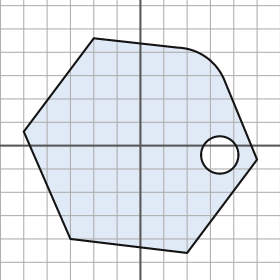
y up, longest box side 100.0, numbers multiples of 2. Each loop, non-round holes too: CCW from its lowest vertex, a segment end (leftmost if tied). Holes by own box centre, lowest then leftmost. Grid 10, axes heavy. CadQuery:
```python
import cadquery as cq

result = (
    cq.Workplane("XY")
    .moveTo(20.0, -46.0)
    .lineTo(50.0, -6.0)
    .lineTo(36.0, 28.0)
    .threePointArc((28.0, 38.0), (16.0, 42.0))
    .lineTo(-20.0, 46.0)
    .lineTo(-50.0, 6.0)
    .lineTo(-30.0, -40.0)
    .close()
    .moveTo(34.0, -4.0)
    .circle(8.0)
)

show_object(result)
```